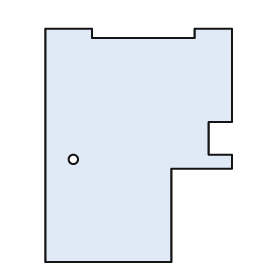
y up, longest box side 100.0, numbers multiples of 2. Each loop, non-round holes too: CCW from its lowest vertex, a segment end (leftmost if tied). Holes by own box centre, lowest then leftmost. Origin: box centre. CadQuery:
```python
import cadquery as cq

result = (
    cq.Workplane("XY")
    .moveTo(-40.0, -50.0)
    .lineTo(14.0, -50.0)
    .lineTo(14.0, -10.0)
    .lineTo(40.0, -10.0)
    .lineTo(40.0, -4.0)
    .lineTo(30.0, -4.0)
    .lineTo(30.0, 10.0)
    .lineTo(40.0, 10.0)
    .lineTo(40.0, 50.0)
    .lineTo(24.0, 50.0)
    .lineTo(24.0, 46.0)
    .lineTo(-20.0, 46.0)
    .lineTo(-20.0, 50.0)
    .lineTo(-40.0, 50.0)
    .close()
    .moveTo(-28.0, -6.0)
    .circle(2.0)
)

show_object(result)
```